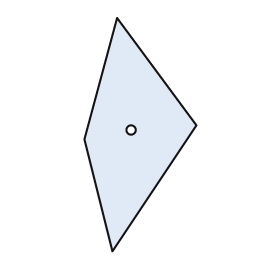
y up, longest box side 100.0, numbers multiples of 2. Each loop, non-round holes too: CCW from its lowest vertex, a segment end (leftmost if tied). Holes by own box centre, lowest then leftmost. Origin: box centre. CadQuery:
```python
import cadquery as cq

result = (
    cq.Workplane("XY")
    .moveTo(-12.0, -50.0)
    .lineTo(24.0, 4.0)
    .lineTo(-10.0, 50.0)
    .lineTo(-24.0, -2.0)
    .close()
    .moveTo(-4.0, 2.0)
    .circle(2.0)
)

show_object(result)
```